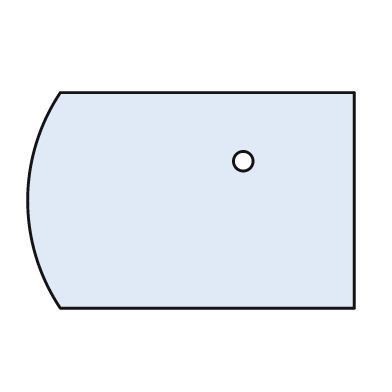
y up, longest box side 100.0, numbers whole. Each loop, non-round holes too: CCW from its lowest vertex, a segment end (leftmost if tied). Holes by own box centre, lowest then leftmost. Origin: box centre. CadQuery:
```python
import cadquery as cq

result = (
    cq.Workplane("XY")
    .moveTo(-40.0, -33.0)
    .lineTo(50.0, -33.0)
    .lineTo(50.0, 33.0)
    .lineTo(-40.0, 33.0)
    .threePointArc((-50.0, 0.0), (-40.0, -33.0))
    .close()
    .moveTo(16.0, 12.0)
    .circle(3.0)
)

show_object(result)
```